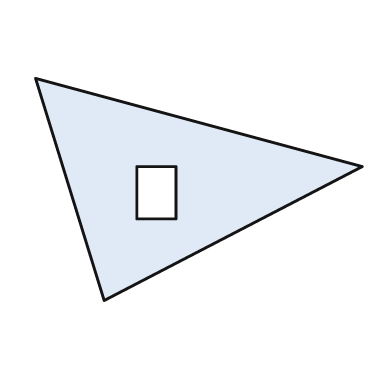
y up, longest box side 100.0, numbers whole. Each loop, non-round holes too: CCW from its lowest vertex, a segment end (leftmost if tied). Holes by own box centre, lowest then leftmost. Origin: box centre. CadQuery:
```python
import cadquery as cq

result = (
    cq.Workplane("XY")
    .moveTo(-29.0, -34.0)
    .lineTo(50.0, 7.0)
    .lineTo(-50.0, 34.0)
    .close()
    .moveTo(-19.0, -9.0)
    .lineTo(-7.0, -9.0)
    .lineTo(-7.0, 7.0)
    .lineTo(-19.0, 7.0)
    .close()
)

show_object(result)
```